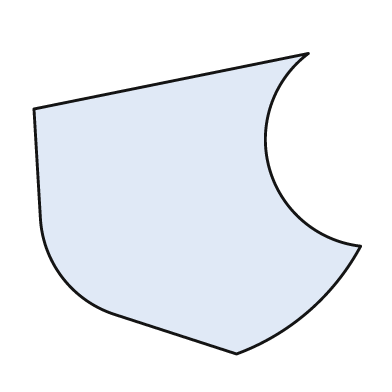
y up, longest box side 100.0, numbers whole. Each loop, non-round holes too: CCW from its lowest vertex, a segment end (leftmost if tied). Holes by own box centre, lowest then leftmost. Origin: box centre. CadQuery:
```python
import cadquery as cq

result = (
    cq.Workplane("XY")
    .moveTo(12.0, -46.0)
    .threePointArc((34.0, -33.0), (50.0, -13.0))
    .threePointArc((22.0, 11.0), (34.0, 46.0))
    .lineTo(-50.0, 29.0)
    .lineTo(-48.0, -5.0)
    .threePointArc((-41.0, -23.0), (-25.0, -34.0))
    .close()
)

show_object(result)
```